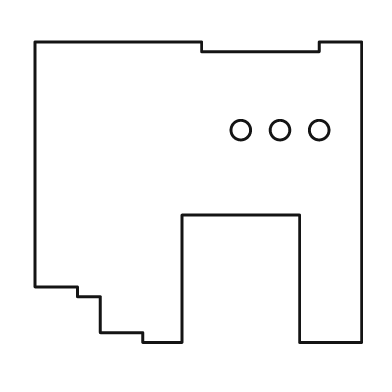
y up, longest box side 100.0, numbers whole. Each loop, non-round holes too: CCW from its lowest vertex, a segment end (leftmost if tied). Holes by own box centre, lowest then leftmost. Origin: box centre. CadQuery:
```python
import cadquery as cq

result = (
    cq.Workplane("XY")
    .moveTo(-17.0, -46.0)
    .lineTo(-5.0, -46.0)
    .lineTo(-5.0, -7.0)
    .lineTo(31.0, -7.0)
    .lineTo(31.0, -46.0)
    .lineTo(50.0, -46.0)
    .lineTo(50.0, 46.0)
    .lineTo(37.0, 46.0)
    .lineTo(37.0, 43.0)
    .lineTo(1.0, 43.0)
    .lineTo(1.0, 46.0)
    .lineTo(-50.0, 46.0)
    .lineTo(-50.0, -29.0)
    .lineTo(-37.0, -29.0)
    .lineTo(-37.0, -32.0)
    .lineTo(-30.0, -32.0)
    .lineTo(-30.0, -43.0)
    .lineTo(-17.0, -43.0)
    .close()
    .moveTo(13.0, 19.0)
    .circle(3.0)
    .moveTo(25.0, 19.0)
    .circle(3.0)
    .moveTo(37.0, 19.0)
    .circle(3.0)
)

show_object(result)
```